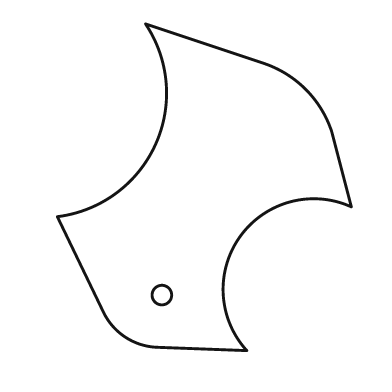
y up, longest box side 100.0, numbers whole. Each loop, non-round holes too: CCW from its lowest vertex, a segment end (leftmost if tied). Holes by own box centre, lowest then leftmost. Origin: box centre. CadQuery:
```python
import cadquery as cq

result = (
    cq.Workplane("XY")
    .moveTo(13.0, -50.0)
    .threePointArc((11.0, -15.0), (45.0, -6.0))
    .lineTo(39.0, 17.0)
    .threePointArc((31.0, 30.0), (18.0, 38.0))
    .lineTo(-18.0, 50.0)
    .threePointArc((-15.0, 13.0), (-45.0, -9.0))
    .lineTo(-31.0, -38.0)
    .threePointArc((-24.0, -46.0), (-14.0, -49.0))
    .close()
    .moveTo(-13.0, -33.0)
    .circle(3.0)
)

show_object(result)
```